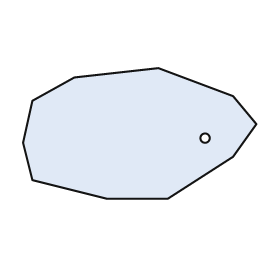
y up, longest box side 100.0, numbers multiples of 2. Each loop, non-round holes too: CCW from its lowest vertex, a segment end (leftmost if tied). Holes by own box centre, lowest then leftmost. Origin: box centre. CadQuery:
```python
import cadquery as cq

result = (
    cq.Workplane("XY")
    .moveTo(-14.0, -28.0)
    .lineTo(12.0, -28.0)
    .lineTo(40.0, -10.0)
    .lineTo(50.0, 4.0)
    .lineTo(40.0, 16.0)
    .lineTo(8.0, 28.0)
    .lineTo(-28.0, 24.0)
    .lineTo(-46.0, 14.0)
    .lineTo(-50.0, -4.0)
    .lineTo(-46.0, -20.0)
    .close()
    .moveTo(28.0, -2.0)
    .circle(2.0)
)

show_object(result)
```